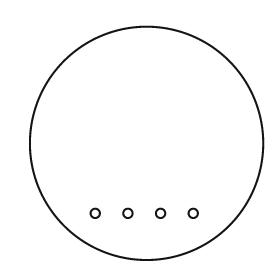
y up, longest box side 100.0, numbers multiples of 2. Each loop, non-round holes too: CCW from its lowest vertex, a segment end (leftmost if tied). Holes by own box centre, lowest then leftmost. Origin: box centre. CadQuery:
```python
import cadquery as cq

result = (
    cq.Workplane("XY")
    .moveTo(0.0, 0.0)
    .circle(50.0)
    .moveTo(-22.0, -30.0)
    .circle(2.0)
    .moveTo(-8.0, -30.0)
    .circle(2.0)
    .moveTo(6.0, -30.0)
    .circle(2.0)
    .moveTo(20.0, -30.0)
    .circle(2.0)
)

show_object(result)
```